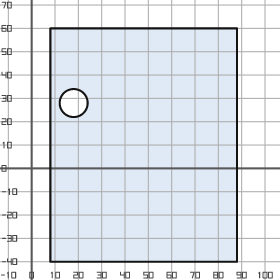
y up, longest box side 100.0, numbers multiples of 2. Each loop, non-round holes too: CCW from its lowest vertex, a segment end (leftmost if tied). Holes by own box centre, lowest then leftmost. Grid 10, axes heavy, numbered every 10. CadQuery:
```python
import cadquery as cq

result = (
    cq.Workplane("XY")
    .moveTo(8.0, -40.0)
    .lineTo(88.0, -40.0)
    .lineTo(88.0, 60.0)
    .lineTo(8.0, 60.0)
    .close()
    .moveTo(18.0, 28.0)
    .circle(6.0)
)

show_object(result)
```